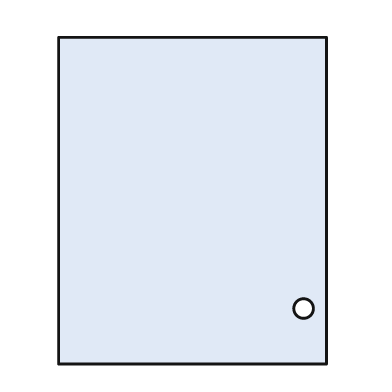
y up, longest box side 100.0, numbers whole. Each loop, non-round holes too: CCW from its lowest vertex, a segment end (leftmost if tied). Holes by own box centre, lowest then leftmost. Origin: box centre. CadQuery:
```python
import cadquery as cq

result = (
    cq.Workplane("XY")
    .moveTo(-41.0, -50.0)
    .lineTo(41.0, -50.0)
    .lineTo(41.0, 50.0)
    .lineTo(-41.0, 50.0)
    .close()
    .moveTo(34.0, -33.0)
    .circle(3.0)
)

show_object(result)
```